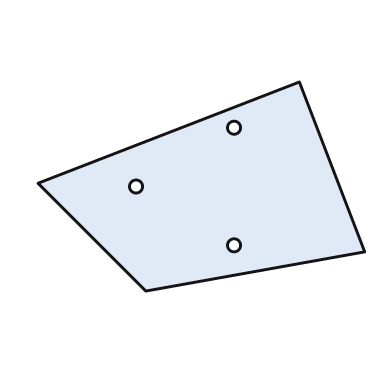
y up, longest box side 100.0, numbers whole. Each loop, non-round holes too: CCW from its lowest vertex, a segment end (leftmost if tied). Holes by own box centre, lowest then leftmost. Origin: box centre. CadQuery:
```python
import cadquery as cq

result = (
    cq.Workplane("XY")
    .moveTo(-17.0, -32.0)
    .lineTo(50.0, -20.0)
    .lineTo(30.0, 32.0)
    .lineTo(-50.0, 1.0)
    .close()
    .moveTo(10.0, -18.0)
    .circle(2.0)
    .moveTo(-20.0, 0.0)
    .circle(2.0)
    .moveTo(10.0, 18.0)
    .circle(2.0)
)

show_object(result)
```